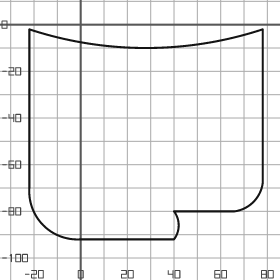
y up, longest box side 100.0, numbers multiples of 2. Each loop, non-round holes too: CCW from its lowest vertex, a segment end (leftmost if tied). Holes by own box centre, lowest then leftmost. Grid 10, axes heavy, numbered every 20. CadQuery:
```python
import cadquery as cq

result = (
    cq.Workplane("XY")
    .moveTo(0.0, -92.0)
    .lineTo(40.0, -92.0)
    .threePointArc((42.0, -86.0), (40.0, -80.0))
    .lineTo(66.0, -80.0)
    .threePointArc((74.0, -76.0), (78.0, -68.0))
    .lineTo(78.0, -2.0)
    .threePointArc((28.0, -10.0), (-22.0, -2.0))
    .lineTo(-22.0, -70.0)
    .threePointArc((-16.0, -86.0), (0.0, -92.0))
    .close()
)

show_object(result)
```